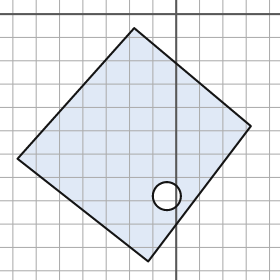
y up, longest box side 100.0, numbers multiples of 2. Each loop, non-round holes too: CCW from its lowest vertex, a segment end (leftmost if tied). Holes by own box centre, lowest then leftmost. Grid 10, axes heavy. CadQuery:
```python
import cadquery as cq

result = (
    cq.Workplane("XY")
    .moveTo(-12.0, -106.0)
    .lineTo(32.0, -48.0)
    .lineTo(-18.0, -6.0)
    .lineTo(-68.0, -62.0)
    .close()
    .moveTo(-4.0, -78.0)
    .circle(6.0)
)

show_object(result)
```